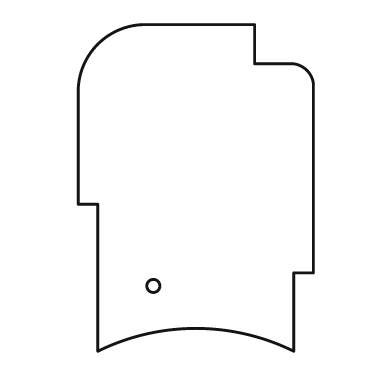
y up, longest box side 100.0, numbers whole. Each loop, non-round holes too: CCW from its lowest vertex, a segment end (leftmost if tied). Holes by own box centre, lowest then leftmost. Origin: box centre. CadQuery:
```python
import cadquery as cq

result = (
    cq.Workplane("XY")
    .moveTo(-30.0, -50.0)
    .threePointArc((0.0, -43.0), (30.0, -50.0))
    .lineTo(30.0, -26.0)
    .lineTo(36.0, -26.0)
    .lineTo(36.0, 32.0)
    .threePointArc((34.0, 36.0), (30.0, 38.0))
    .lineTo(18.0, 38.0)
    .lineTo(18.0, 50.0)
    .lineTo(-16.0, 50.0)
    .threePointArc((-30.0, 44.0), (-36.0, 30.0))
    .lineTo(-36.0, -5.0)
    .lineTo(-30.0, -5.0)
    .close()
    .moveTo(-13.0, -30.0)
    .circle(2.0)
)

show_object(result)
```